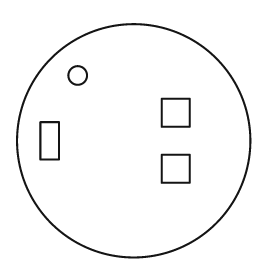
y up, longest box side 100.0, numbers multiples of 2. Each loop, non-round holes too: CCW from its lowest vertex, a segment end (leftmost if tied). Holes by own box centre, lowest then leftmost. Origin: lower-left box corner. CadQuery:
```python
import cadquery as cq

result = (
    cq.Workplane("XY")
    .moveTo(50.0, 50.0)
    .circle(50.0)
    .moveTo(62.0, 32.0)
    .lineTo(74.0, 32.0)
    .lineTo(74.0, 44.0)
    .lineTo(62.0, 44.0)
    .close()
    .moveTo(10.0, 42.0)
    .lineTo(18.0, 42.0)
    .lineTo(18.0, 58.0)
    .lineTo(10.0, 58.0)
    .close()
    .moveTo(62.0, 56.0)
    .lineTo(74.0, 56.0)
    .lineTo(74.0, 68.0)
    .lineTo(62.0, 68.0)
    .close()
    .moveTo(26.0, 78.0)
    .circle(4.0)
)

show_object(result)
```